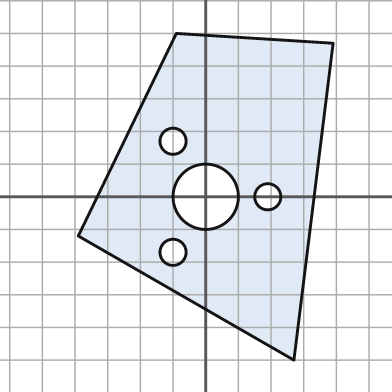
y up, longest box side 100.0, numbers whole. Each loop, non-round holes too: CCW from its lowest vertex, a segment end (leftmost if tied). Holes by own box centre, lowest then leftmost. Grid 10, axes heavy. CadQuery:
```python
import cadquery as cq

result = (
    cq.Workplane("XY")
    .moveTo(27.0, -50.0)
    .lineTo(39.0, 47.0)
    .lineTo(-9.0, 50.0)
    .lineTo(-39.0, -12.0)
    .close()
    .moveTo(-10.0, -17.0)
    .circle(4.0)
    .moveTo(0.0, 0.0)
    .circle(10.0)
    .moveTo(19.0, 0.0)
    .circle(4.0)
    .moveTo(-10.0, 17.0)
    .circle(4.0)
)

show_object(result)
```